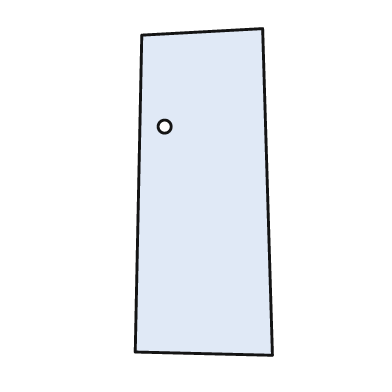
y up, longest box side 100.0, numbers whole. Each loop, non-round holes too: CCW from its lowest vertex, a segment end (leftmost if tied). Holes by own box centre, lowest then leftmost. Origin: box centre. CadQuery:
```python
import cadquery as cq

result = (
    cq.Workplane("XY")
    .moveTo(21.0, -50.0)
    .lineTo(18.0, 50.0)
    .lineTo(-19.0, 48.0)
    .lineTo(-21.0, -49.0)
    .close()
    .moveTo(-12.0, 20.0)
    .circle(2.0)
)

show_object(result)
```